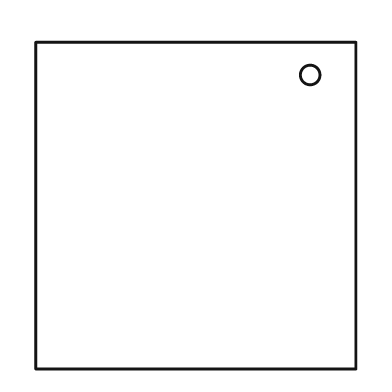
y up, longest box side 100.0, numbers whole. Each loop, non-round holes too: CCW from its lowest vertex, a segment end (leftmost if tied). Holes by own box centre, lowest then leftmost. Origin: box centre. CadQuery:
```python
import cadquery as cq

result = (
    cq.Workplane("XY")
    .moveTo(-49.0, -50.0)
    .lineTo(49.0, -50.0)
    .lineTo(49.0, 50.0)
    .lineTo(-49.0, 50.0)
    .close()
    .moveTo(35.0, 40.0)
    .circle(3.0)
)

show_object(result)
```